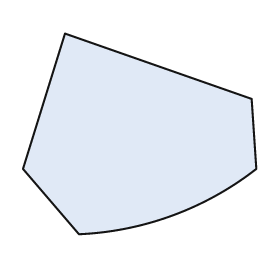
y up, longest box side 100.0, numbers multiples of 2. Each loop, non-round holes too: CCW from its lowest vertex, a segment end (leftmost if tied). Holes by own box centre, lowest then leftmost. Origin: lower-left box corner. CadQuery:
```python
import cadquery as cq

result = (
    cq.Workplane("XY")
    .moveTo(24.0, 0.0)
    .threePointArc((64.0, 8.0), (100.0, 28.0))
    .lineTo(98.0, 58.0)
    .lineTo(18.0, 86.0)
    .lineTo(0.0, 28.0)
    .close()
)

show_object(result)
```